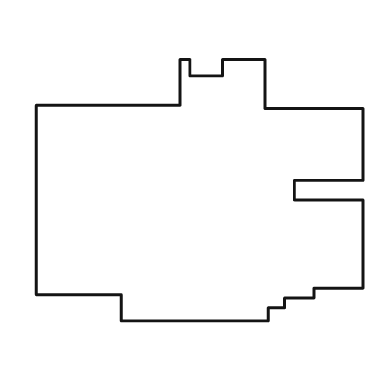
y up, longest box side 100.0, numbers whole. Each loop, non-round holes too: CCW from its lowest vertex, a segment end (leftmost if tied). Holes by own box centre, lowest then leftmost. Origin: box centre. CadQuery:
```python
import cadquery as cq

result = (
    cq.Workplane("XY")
    .moveTo(-24.0, -40.0)
    .lineTo(21.0, -40.0)
    .lineTo(21.0, -36.0)
    .lineTo(26.0, -36.0)
    .lineTo(26.0, -33.0)
    .lineTo(35.0, -33.0)
    .lineTo(35.0, -30.0)
    .lineTo(50.0, -30.0)
    .lineTo(50.0, -3.0)
    .lineTo(29.0, -3.0)
    .lineTo(29.0, 3.0)
    .lineTo(50.0, 3.0)
    .lineTo(50.0, 25.0)
    .lineTo(20.0, 25.0)
    .lineTo(20.0, 40.0)
    .lineTo(7.0, 40.0)
    .lineTo(7.0, 35.0)
    .lineTo(-3.0, 35.0)
    .lineTo(-3.0, 40.0)
    .lineTo(-6.0, 40.0)
    .lineTo(-6.0, 26.0)
    .lineTo(-50.0, 26.0)
    .lineTo(-50.0, -32.0)
    .lineTo(-24.0, -32.0)
    .close()
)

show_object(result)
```